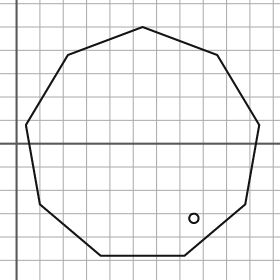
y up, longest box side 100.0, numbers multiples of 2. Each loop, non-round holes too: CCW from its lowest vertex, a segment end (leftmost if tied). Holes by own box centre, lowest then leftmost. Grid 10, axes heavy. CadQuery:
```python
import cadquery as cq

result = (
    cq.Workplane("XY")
    .moveTo(36.0, -48.0)
    .lineTo(72.0, -48.0)
    .lineTo(98.0, -26.0)
    .lineTo(104.0, 8.0)
    .lineTo(86.0, 38.0)
    .lineTo(54.0, 50.0)
    .lineTo(22.0, 38.0)
    .lineTo(4.0, 8.0)
    .lineTo(10.0, -26.0)
    .close()
    .moveTo(76.0, -32.0)
    .circle(2.0)
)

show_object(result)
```